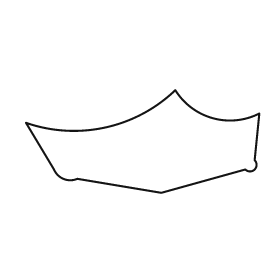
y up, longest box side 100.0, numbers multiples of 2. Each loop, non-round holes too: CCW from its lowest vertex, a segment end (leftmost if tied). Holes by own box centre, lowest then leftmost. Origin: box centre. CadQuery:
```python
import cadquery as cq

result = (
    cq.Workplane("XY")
    .moveTo(8.0, -22.0)
    .lineTo(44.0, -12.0)
    .threePointArc((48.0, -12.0), (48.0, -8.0))
    .lineTo(50.0, 12.0)
    .threePointArc((30.0, 10.0), (14.0, 22.0))
    .threePointArc((-16.0, 6.0), (-50.0, 8.0))
    .lineTo(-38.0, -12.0)
    .threePointArc((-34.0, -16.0), (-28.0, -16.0))
    .close()
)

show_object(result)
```